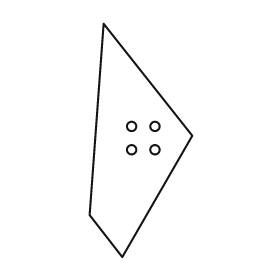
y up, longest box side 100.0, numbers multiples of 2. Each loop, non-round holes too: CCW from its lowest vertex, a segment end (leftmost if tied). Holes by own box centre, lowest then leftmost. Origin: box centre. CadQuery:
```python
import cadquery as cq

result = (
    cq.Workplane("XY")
    .moveTo(-8.0, -50.0)
    .lineTo(22.0, 2.0)
    .lineTo(-16.0, 50.0)
    .lineTo(-22.0, -32.0)
    .close()
    .moveTo(-4.0, -4.0)
    .circle(2.0)
    .moveTo(6.0, -4.0)
    .circle(2.0)
    .moveTo(-4.0, 6.0)
    .circle(2.0)
    .moveTo(6.0, 6.0)
    .circle(2.0)
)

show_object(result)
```